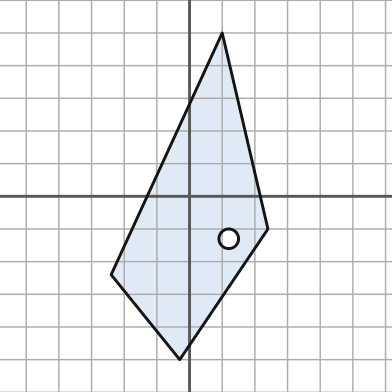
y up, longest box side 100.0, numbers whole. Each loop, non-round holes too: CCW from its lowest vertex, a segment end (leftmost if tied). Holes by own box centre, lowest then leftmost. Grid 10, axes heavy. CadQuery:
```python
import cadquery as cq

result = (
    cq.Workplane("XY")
    .moveTo(-3.0, -50.0)
    .lineTo(24.0, -10.0)
    .lineTo(10.0, 50.0)
    .lineTo(-24.0, -24.0)
    .close()
    .moveTo(12.0, -13.0)
    .circle(3.0)
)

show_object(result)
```